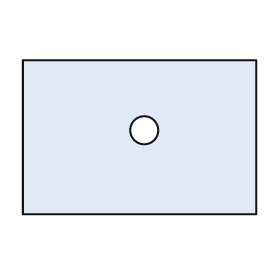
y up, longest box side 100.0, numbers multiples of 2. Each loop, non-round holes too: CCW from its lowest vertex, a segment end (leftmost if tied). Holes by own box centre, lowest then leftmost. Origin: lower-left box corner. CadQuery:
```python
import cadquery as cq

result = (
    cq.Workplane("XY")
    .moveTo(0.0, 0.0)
    .lineTo(100.0, 0.0)
    .lineTo(100.0, 66.0)
    .lineTo(0.0, 66.0)
    .close()
    .moveTo(52.0, 36.0)
    .circle(6.0)
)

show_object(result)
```